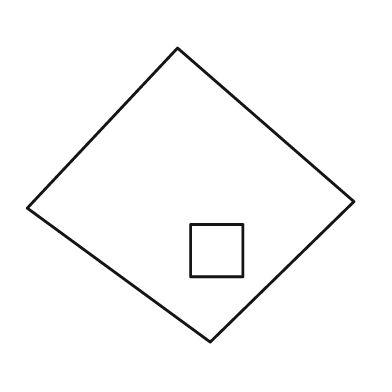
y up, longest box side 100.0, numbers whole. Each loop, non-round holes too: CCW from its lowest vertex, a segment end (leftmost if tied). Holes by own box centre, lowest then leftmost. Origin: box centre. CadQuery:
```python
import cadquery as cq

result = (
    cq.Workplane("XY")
    .moveTo(6.0, -45.0)
    .lineTo(50.0, -2.0)
    .lineTo(-4.0, 45.0)
    .lineTo(-50.0, -4.0)
    .close()
    .moveTo(0.0, -25.0)
    .lineTo(16.0, -25.0)
    .lineTo(16.0, -9.0)
    .lineTo(0.0, -9.0)
    .close()
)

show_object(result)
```